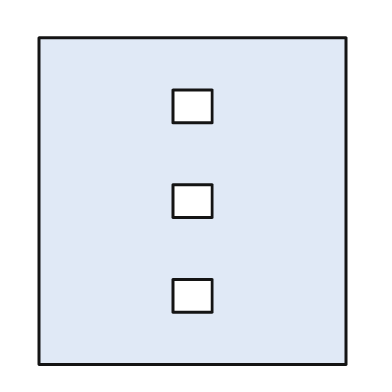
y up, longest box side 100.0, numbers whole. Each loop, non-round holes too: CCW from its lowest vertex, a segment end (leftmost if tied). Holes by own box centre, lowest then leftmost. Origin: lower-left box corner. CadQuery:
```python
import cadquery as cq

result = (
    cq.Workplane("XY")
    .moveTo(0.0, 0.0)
    .lineTo(94.0, 0.0)
    .lineTo(94.0, 100.0)
    .lineTo(0.0, 100.0)
    .close()
    .moveTo(41.0, 16.0)
    .lineTo(53.0, 16.0)
    .lineTo(53.0, 26.0)
    .lineTo(41.0, 26.0)
    .close()
    .moveTo(41.0, 45.0)
    .lineTo(53.0, 45.0)
    .lineTo(53.0, 55.0)
    .lineTo(41.0, 55.0)
    .close()
    .moveTo(41.0, 74.0)
    .lineTo(53.0, 74.0)
    .lineTo(53.0, 84.0)
    .lineTo(41.0, 84.0)
    .close()
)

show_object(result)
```